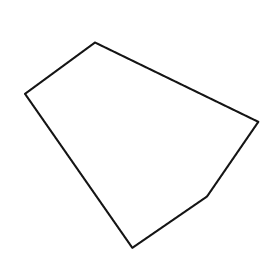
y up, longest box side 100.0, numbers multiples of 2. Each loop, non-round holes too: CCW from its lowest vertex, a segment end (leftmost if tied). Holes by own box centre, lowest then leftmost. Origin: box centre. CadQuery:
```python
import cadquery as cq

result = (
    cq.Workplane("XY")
    .moveTo(-4.0, -44.0)
    .lineTo(28.0, -22.0)
    .lineTo(50.0, 10.0)
    .lineTo(-20.0, 44.0)
    .lineTo(-50.0, 22.0)
    .close()
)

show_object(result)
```